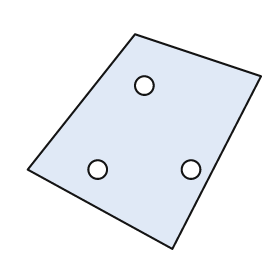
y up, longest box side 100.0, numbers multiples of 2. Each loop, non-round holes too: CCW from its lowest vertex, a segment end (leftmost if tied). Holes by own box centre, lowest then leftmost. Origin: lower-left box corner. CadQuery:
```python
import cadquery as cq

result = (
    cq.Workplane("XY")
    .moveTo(62.0, 0.0)
    .lineTo(100.0, 74.0)
    .lineTo(46.0, 92.0)
    .lineTo(0.0, 34.0)
    .close()
    .moveTo(30.0, 34.0)
    .circle(4.0)
    .moveTo(70.0, 34.0)
    .circle(4.0)
    .moveTo(50.0, 70.0)
    .circle(4.0)
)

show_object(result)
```